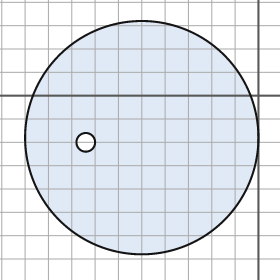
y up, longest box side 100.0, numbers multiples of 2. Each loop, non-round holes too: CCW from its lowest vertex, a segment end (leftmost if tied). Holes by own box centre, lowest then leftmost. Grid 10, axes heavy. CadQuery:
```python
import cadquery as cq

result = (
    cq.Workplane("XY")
    .moveTo(-50.0, -18.0)
    .circle(50.0)
    .moveTo(-74.0, -20.0)
    .circle(4.0)
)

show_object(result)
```